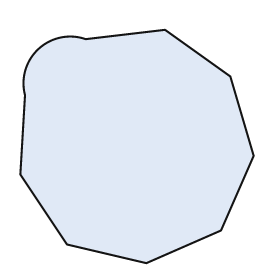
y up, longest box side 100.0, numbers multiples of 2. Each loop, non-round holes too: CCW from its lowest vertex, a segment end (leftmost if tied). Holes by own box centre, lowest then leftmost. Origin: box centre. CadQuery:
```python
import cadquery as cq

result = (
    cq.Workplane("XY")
    .moveTo(4.0, -50.0)
    .lineTo(36.0, -36.0)
    .lineTo(50.0, -4.0)
    .lineTo(40.0, 30.0)
    .lineTo(12.0, 50.0)
    .lineTo(-22.0, 46.0)
    .threePointArc((-42.0, 42.0), (-48.0, 22.0))
    .lineTo(-50.0, -12.0)
    .lineTo(-30.0, -42.0)
    .close()
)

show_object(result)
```